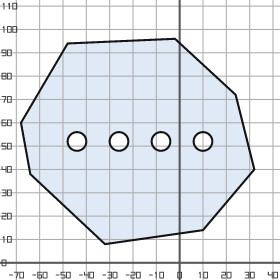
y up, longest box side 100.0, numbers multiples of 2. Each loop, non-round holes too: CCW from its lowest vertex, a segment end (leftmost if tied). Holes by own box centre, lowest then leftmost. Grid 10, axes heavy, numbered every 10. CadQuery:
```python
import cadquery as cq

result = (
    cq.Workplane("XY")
    .moveTo(-32.0, 8.0)
    .lineTo(10.0, 14.0)
    .lineTo(32.0, 40.0)
    .lineTo(24.0, 72.0)
    .lineTo(-2.0, 96.0)
    .lineTo(-48.0, 94.0)
    .lineTo(-68.0, 60.0)
    .lineTo(-64.0, 38.0)
    .close()
    .moveTo(-44.0, 52.0)
    .circle(4.0)
    .moveTo(-26.0, 52.0)
    .circle(4.0)
    .moveTo(-8.0, 52.0)
    .circle(4.0)
    .moveTo(10.0, 52.0)
    .circle(4.0)
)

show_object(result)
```